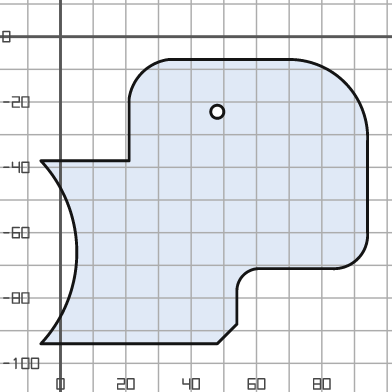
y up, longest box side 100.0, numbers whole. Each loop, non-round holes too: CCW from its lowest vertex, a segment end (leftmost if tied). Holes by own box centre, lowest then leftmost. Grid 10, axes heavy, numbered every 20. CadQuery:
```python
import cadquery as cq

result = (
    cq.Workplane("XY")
    .moveTo(-6.0, -94.0)
    .lineTo(48.0, -94.0)
    .lineTo(54.0, -88.0)
    .lineTo(54.0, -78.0)
    .threePointArc((56.0, -73.0), (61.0, -71.0))
    .lineTo(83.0, -71.0)
    .threePointArc((91.0, -68.0), (94.0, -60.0))
    .lineTo(94.0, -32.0)
    .threePointArc((87.0, -14.0), (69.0, -7.0))
    .lineTo(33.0, -7.0)
    .threePointArc((25.0, -11.0), (21.0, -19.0))
    .lineTo(21.0, -38.0)
    .lineTo(-6.0, -38.0)
    .threePointArc((5.0, -66.0), (-6.0, -94.0))
    .close()
    .moveTo(48.0, -23.0)
    .circle(2.0)
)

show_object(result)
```